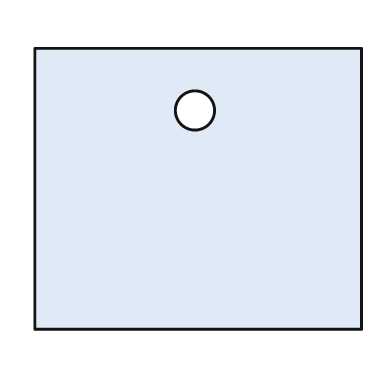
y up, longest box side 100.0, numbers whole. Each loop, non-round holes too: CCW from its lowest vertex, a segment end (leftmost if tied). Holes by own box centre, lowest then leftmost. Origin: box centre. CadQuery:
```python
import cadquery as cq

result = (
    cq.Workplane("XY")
    .moveTo(-50.0, -43.0)
    .lineTo(50.0, -43.0)
    .lineTo(50.0, 43.0)
    .lineTo(-50.0, 43.0)
    .close()
    .moveTo(-1.0, 24.0)
    .circle(6.0)
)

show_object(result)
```